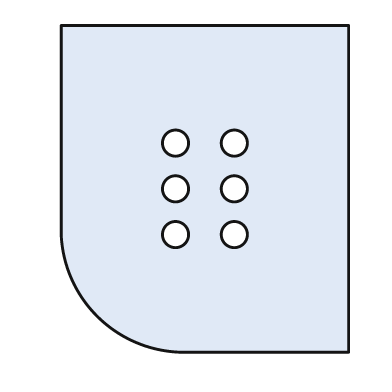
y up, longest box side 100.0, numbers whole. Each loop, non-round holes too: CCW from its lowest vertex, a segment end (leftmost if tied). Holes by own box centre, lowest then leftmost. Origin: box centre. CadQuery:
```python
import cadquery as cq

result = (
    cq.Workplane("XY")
    .moveTo(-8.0, -50.0)
    .lineTo(44.0, -50.0)
    .lineTo(44.0, 50.0)
    .lineTo(-44.0, 50.0)
    .lineTo(-44.0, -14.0)
    .threePointArc((-33.0, -39.0), (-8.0, -50.0))
    .close()
    .moveTo(-9.0, -14.0)
    .circle(4.0)
    .moveTo(9.0, -14.0)
    .circle(4.0)
    .moveTo(-9.0, 0.0)
    .circle(4.0)
    .moveTo(9.0, 0.0)
    .circle(4.0)
    .moveTo(-9.0, 14.0)
    .circle(4.0)
    .moveTo(9.0, 14.0)
    .circle(4.0)
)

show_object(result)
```